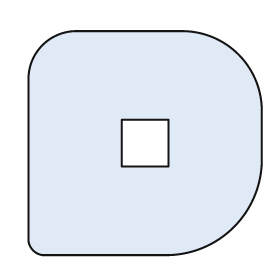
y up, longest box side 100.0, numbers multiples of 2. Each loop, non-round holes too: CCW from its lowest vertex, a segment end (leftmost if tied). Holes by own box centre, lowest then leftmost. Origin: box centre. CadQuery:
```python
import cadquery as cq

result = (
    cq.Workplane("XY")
    .moveTo(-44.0, -48.0)
    .lineTo(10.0, -48.0)
    .threePointArc((38.0, -36.0), (50.0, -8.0))
    .lineTo(50.0, 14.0)
    .threePointArc((40.0, 38.0), (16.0, 48.0))
    .lineTo(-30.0, 48.0)
    .threePointArc((-44.0, 42.0), (-50.0, 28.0))
    .lineTo(-50.0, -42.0)
    .threePointArc((-48.0, -46.0), (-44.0, -48.0))
    .close()
    .moveTo(-10.0, -10.0)
    .lineTo(10.0, -10.0)
    .lineTo(10.0, 10.0)
    .lineTo(-10.0, 10.0)
    .close()
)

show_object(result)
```